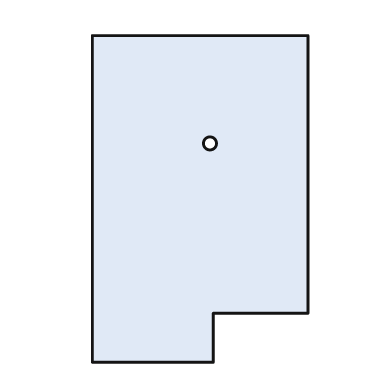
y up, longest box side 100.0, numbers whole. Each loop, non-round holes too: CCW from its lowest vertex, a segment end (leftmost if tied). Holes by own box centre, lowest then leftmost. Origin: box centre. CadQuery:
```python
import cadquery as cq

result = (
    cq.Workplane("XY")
    .moveTo(-33.0, -50.0)
    .lineTo(4.0, -50.0)
    .lineTo(4.0, -35.0)
    .lineTo(33.0, -35.0)
    .lineTo(33.0, 50.0)
    .lineTo(-33.0, 50.0)
    .close()
    .moveTo(3.0, 17.0)
    .circle(2.0)
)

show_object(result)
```